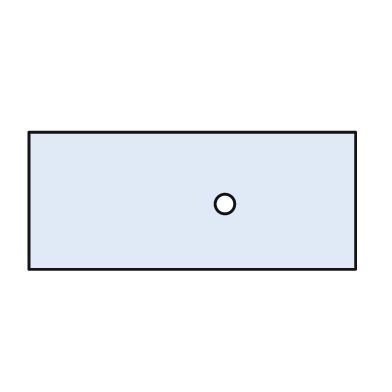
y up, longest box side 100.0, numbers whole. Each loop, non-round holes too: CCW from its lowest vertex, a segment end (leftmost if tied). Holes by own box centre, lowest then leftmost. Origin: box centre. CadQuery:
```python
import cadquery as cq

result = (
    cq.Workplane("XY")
    .moveTo(-50.0, -21.0)
    .lineTo(50.0, -21.0)
    .lineTo(50.0, 21.0)
    .lineTo(-50.0, 21.0)
    .close()
    .moveTo(10.0, -1.0)
    .circle(3.0)
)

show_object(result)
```